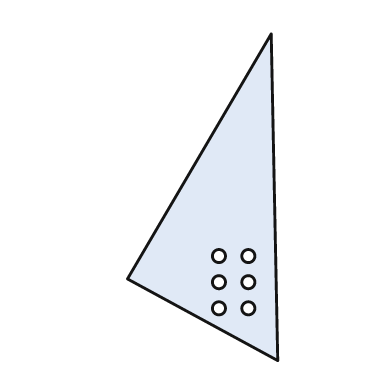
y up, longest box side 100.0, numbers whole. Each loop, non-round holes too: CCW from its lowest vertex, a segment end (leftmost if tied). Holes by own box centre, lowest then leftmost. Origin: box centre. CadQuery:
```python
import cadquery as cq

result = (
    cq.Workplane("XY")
    .moveTo(23.0, -50.0)
    .lineTo(21.0, 50.0)
    .lineTo(-23.0, -25.0)
    .close()
    .moveTo(5.0, -34.0)
    .circle(2.0)
    .moveTo(14.0, -34.0)
    .circle(2.0)
    .moveTo(5.0, -26.0)
    .circle(2.0)
    .moveTo(14.0, -26.0)
    .circle(2.0)
    .moveTo(5.0, -18.0)
    .circle(2.0)
    .moveTo(14.0, -18.0)
    .circle(2.0)
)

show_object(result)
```